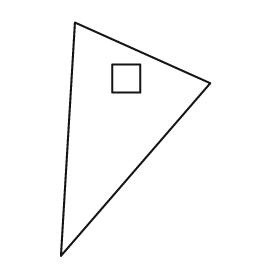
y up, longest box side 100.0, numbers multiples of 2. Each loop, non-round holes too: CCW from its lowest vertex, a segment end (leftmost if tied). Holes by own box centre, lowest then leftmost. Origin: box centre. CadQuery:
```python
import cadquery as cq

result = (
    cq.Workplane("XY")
    .moveTo(-32.0, -50.0)
    .lineTo(32.0, 24.0)
    .lineTo(-26.0, 50.0)
    .close()
    .moveTo(-10.0, 20.0)
    .lineTo(2.0, 20.0)
    .lineTo(2.0, 32.0)
    .lineTo(-10.0, 32.0)
    .close()
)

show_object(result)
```